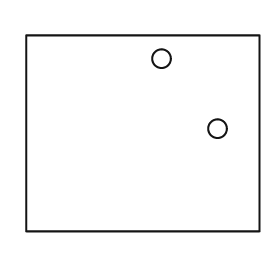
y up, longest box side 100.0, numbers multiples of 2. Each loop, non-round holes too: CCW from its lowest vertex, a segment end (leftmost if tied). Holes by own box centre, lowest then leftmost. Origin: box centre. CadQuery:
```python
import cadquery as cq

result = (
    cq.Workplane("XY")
    .moveTo(-50.0, -42.0)
    .lineTo(50.0, -42.0)
    .lineTo(50.0, 42.0)
    .lineTo(-50.0, 42.0)
    .close()
    .moveTo(32.0, 2.0)
    .circle(4.0)
    .moveTo(8.0, 32.0)
    .circle(4.0)
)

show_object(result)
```